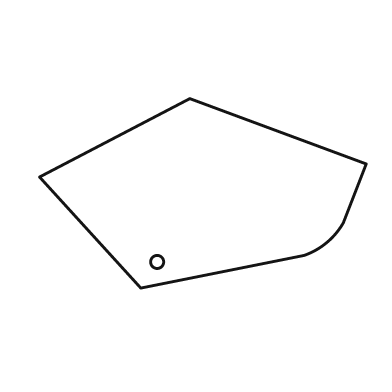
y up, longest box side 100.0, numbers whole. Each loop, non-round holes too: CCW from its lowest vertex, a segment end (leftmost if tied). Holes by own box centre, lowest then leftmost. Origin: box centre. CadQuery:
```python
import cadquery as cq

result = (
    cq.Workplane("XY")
    .moveTo(-19.0, -29.0)
    .lineTo(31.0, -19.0)
    .threePointArc((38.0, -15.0), (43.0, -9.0))
    .lineTo(50.0, 9.0)
    .lineTo(-4.0, 29.0)
    .lineTo(-50.0, 5.0)
    .close()
    .moveTo(-14.0, -21.0)
    .circle(2.0)
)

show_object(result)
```